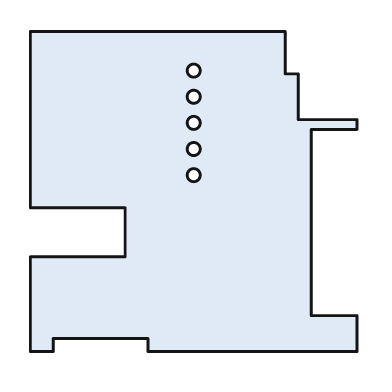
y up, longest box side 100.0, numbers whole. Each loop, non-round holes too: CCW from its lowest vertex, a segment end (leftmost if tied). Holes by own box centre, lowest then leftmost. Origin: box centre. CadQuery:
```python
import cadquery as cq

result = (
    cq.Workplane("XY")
    .moveTo(-50.0, -49.0)
    .lineTo(-43.0, -49.0)
    .lineTo(-43.0, -45.0)
    .lineTo(-14.0, -45.0)
    .lineTo(-14.0, -49.0)
    .lineTo(50.0, -49.0)
    .lineTo(50.0, -38.0)
    .lineTo(36.0, -38.0)
    .lineTo(36.0, 19.0)
    .lineTo(50.0, 19.0)
    .lineTo(50.0, 22.0)
    .lineTo(32.0, 22.0)
    .lineTo(32.0, 36.0)
    .lineTo(28.0, 36.0)
    .lineTo(28.0, 49.0)
    .lineTo(-50.0, 49.0)
    .lineTo(-50.0, -5.0)
    .lineTo(-21.0, -5.0)
    .lineTo(-21.0, -20.0)
    .lineTo(-50.0, -20.0)
    .close()
    .moveTo(0.0, 5.0)
    .circle(2.0)
    .moveTo(0.0, 13.0)
    .circle(2.0)
    .moveTo(0.0, 21.0)
    .circle(2.0)
    .moveTo(0.0, 29.0)
    .circle(2.0)
    .moveTo(0.0, 37.0)
    .circle(2.0)
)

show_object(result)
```